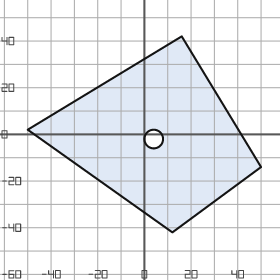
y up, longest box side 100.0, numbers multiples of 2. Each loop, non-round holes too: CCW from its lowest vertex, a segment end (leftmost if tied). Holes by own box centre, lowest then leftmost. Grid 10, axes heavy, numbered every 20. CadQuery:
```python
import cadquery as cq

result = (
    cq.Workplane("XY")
    .moveTo(12.0, -42.0)
    .lineTo(50.0, -14.0)
    .lineTo(16.0, 42.0)
    .lineTo(-50.0, 2.0)
    .close()
    .moveTo(4.0, -2.0)
    .circle(4.0)
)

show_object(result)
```